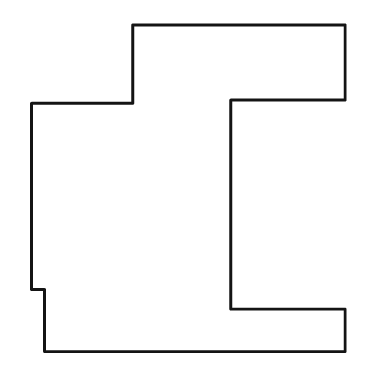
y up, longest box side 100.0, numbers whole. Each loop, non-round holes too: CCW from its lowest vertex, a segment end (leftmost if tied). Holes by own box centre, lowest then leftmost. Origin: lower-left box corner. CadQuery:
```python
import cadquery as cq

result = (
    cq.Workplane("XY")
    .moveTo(4.0, 0.0)
    .lineTo(96.0, 0.0)
    .lineTo(96.0, 13.0)
    .lineTo(61.0, 13.0)
    .lineTo(61.0, 77.0)
    .lineTo(96.0, 77.0)
    .lineTo(96.0, 100.0)
    .lineTo(31.0, 100.0)
    .lineTo(31.0, 76.0)
    .lineTo(0.0, 76.0)
    .lineTo(0.0, 19.0)
    .lineTo(4.0, 19.0)
    .close()
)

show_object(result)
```